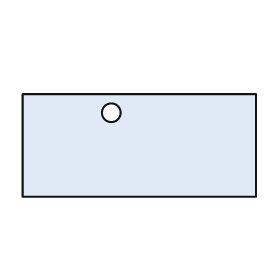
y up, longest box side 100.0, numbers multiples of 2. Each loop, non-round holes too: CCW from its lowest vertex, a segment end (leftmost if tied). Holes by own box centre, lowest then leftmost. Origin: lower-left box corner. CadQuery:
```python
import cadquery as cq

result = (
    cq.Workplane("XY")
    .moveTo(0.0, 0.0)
    .lineTo(100.0, 0.0)
    .lineTo(100.0, 44.0)
    .lineTo(0.0, 44.0)
    .close()
    .moveTo(38.0, 36.0)
    .circle(4.0)
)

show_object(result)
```